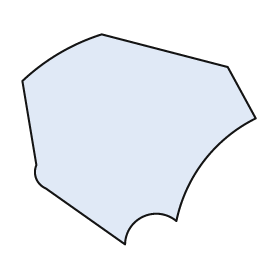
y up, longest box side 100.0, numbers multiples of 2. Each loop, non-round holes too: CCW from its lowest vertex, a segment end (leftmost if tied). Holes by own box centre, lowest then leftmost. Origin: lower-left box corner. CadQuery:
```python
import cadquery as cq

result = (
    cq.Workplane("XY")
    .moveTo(44.0, 0.0)
    .threePointArc((52.0, 12.0), (66.0, 10.0))
    .threePointArc((78.0, 36.0), (100.0, 54.0))
    .lineTo(88.0, 76.0)
    .lineTo(34.0, 90.0)
    .threePointArc((16.0, 82.0), (0.0, 70.0))
    .lineTo(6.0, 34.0)
    .threePointArc((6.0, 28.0), (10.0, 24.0))
    .close()
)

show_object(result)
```